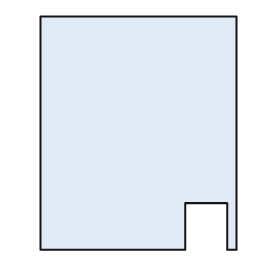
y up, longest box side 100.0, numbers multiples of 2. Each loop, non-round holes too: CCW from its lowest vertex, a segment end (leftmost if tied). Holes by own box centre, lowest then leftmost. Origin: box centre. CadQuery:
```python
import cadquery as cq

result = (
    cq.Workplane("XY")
    .moveTo(-42.0, -50.0)
    .lineTo(20.0, -50.0)
    .lineTo(20.0, -30.0)
    .lineTo(38.0, -30.0)
    .lineTo(38.0, -50.0)
    .lineTo(42.0, -50.0)
    .lineTo(42.0, 50.0)
    .lineTo(-42.0, 50.0)
    .close()
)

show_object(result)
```